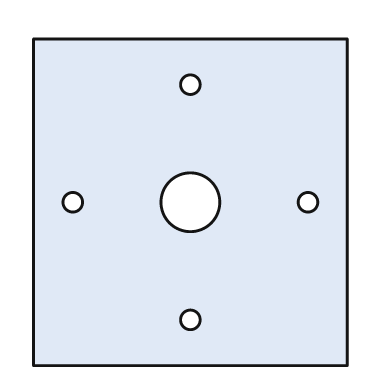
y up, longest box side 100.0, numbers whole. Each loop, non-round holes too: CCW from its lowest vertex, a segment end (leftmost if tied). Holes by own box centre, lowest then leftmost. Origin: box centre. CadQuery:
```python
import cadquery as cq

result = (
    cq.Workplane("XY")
    .moveTo(-48.0, -50.0)
    .lineTo(48.0, -50.0)
    .lineTo(48.0, 50.0)
    .lineTo(-48.0, 50.0)
    .close()
    .moveTo(0.0, -36.0)
    .circle(3.0)
    .moveTo(-36.0, 0.0)
    .circle(3.0)
    .moveTo(0.0, 0.0)
    .circle(9.0)
    .moveTo(36.0, 0.0)
    .circle(3.0)
    .moveTo(0.0, 36.0)
    .circle(3.0)
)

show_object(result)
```